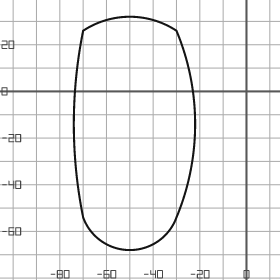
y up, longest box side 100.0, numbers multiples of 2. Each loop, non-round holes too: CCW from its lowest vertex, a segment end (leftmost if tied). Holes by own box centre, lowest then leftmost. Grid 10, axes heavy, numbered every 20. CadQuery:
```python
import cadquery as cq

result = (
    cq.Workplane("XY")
    .moveTo(-70.0, -54.0)
    .threePointArc((-50.0, -68.0), (-30.0, -54.0))
    .threePointArc((-22.0, -14.0), (-30.0, 26.0))
    .threePointArc((-50.0, 32.0), (-70.0, 26.0))
    .threePointArc((-74.0, -14.0), (-70.0, -54.0))
    .close()
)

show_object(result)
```